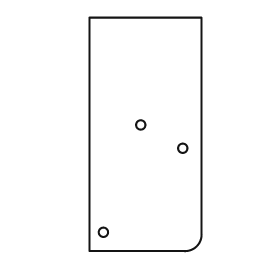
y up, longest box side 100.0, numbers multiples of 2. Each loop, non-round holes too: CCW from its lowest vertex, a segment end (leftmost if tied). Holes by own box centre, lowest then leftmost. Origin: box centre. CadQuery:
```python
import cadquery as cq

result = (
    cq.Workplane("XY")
    .moveTo(-24.0, -50.0)
    .lineTo(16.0, -50.0)
    .threePointArc((22.0, -48.0), (24.0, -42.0))
    .lineTo(24.0, 50.0)
    .lineTo(-24.0, 50.0)
    .close()
    .moveTo(-18.0, -42.0)
    .circle(2.0)
    .moveTo(16.0, -6.0)
    .circle(2.0)
    .moveTo(-2.0, 4.0)
    .circle(2.0)
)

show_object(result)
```